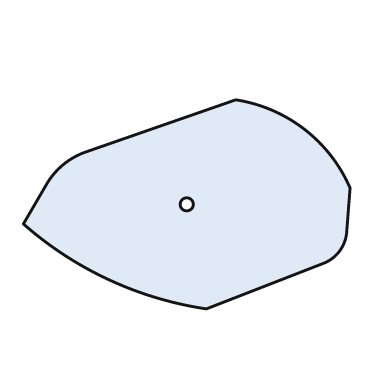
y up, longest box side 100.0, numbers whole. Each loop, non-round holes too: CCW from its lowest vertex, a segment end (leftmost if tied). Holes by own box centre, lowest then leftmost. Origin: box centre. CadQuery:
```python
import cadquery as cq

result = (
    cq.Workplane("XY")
    .moveTo(6.0, -32.0)
    .lineTo(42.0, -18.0)
    .threePointArc((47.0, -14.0), (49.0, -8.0))
    .lineTo(50.0, 5.0)
    .threePointArc((36.0, 23.0), (15.0, 32.0))
    .lineTo(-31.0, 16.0)
    .threePointArc((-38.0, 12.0), (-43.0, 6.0))
    .lineTo(-50.0, -6.0)
    .threePointArc((-24.0, -23.0), (6.0, -32.0))
    .close()
    .moveTo(0.0, 0.0)
    .circle(2.0)
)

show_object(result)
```